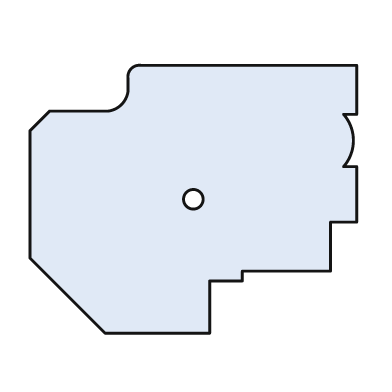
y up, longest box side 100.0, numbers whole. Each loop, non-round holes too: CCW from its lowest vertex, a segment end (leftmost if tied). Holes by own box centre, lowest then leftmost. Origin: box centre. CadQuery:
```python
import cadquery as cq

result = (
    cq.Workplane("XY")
    .moveTo(-27.0, -41.0)
    .lineTo(5.0, -41.0)
    .lineTo(5.0, -25.0)
    .lineTo(15.0, -25.0)
    .lineTo(15.0, -22.0)
    .lineTo(42.0, -22.0)
    .lineTo(42.0, -7.0)
    .lineTo(50.0, -7.0)
    .lineTo(50.0, 10.0)
    .lineTo(46.0, 10.0)
    .threePointArc((49.0, 18.0), (46.0, 26.0))
    .lineTo(50.0, 26.0)
    .lineTo(50.0, 41.0)
    .lineTo(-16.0, 41.0)
    .threePointArc((-19.0, 40.0), (-20.0, 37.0))
    .lineTo(-20.0, 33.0)
    .threePointArc((-22.0, 29.0), (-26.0, 27.0))
    .lineTo(-44.0, 27.0)
    .lineTo(-50.0, 21.0)
    .lineTo(-50.0, -18.0)
    .close()
    .moveTo(0.0, 0.0)
    .circle(3.0)
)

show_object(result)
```